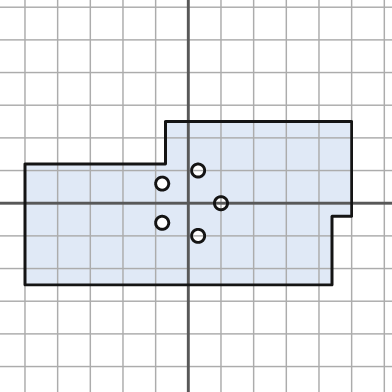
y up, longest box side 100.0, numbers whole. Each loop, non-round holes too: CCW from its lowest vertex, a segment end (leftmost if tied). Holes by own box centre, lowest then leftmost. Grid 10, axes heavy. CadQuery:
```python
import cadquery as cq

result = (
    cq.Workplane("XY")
    .moveTo(-50.0, -25.0)
    .lineTo(44.0, -25.0)
    .lineTo(44.0, -4.0)
    .lineTo(50.0, -4.0)
    .lineTo(50.0, 25.0)
    .lineTo(-7.0, 25.0)
    .lineTo(-7.0, 12.0)
    .lineTo(-50.0, 12.0)
    .close()
    .moveTo(3.0, -10.0)
    .circle(2.0)
    .moveTo(-8.0, -6.0)
    .circle(2.0)
    .moveTo(10.0, 0.0)
    .circle(2.0)
    .moveTo(-8.0, 6.0)
    .circle(2.0)
    .moveTo(3.0, 10.0)
    .circle(2.0)
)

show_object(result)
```